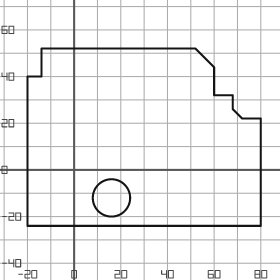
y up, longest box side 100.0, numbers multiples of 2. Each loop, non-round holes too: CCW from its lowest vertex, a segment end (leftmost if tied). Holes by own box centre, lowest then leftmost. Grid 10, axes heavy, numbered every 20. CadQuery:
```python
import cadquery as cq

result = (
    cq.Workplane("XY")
    .moveTo(-20.0, -24.0)
    .lineTo(80.0, -24.0)
    .lineTo(80.0, 22.0)
    .lineTo(72.0, 22.0)
    .lineTo(68.0, 26.0)
    .lineTo(68.0, 32.0)
    .lineTo(60.0, 32.0)
    .lineTo(60.0, 44.0)
    .lineTo(52.0, 52.0)
    .lineTo(-14.0, 52.0)
    .lineTo(-14.0, 40.0)
    .lineTo(-20.0, 40.0)
    .close()
    .moveTo(16.0, -12.0)
    .circle(8.0)
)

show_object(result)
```